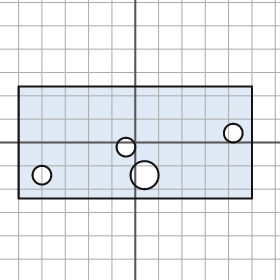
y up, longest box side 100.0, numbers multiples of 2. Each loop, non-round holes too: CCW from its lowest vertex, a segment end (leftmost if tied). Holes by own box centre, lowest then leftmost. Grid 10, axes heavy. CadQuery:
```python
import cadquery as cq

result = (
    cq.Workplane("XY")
    .moveTo(-50.0, -24.0)
    .lineTo(50.0, -24.0)
    .lineTo(50.0, 24.0)
    .lineTo(-50.0, 24.0)
    .close()
    .moveTo(-40.0, -14.0)
    .circle(4.0)
    .moveTo(4.0, -14.0)
    .circle(6.0)
    .moveTo(-4.0, -2.0)
    .circle(4.0)
    .moveTo(42.0, 4.0)
    .circle(4.0)
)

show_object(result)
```